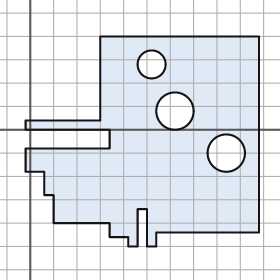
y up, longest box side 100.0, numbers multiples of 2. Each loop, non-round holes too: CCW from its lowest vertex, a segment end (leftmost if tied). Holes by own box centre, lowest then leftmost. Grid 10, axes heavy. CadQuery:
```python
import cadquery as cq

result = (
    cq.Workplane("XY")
    .moveTo(42.0, -50.0)
    .lineTo(46.0, -50.0)
    .lineTo(46.0, -34.0)
    .lineTo(50.0, -34.0)
    .lineTo(50.0, -50.0)
    .lineTo(54.0, -50.0)
    .lineTo(54.0, -44.0)
    .lineTo(98.0, -44.0)
    .lineTo(98.0, 40.0)
    .lineTo(30.0, 40.0)
    .lineTo(30.0, 4.0)
    .lineTo(-2.0, 4.0)
    .lineTo(-2.0, 0.0)
    .lineTo(34.0, 0.0)
    .lineTo(34.0, -8.0)
    .lineTo(-2.0, -8.0)
    .lineTo(-2.0, -18.0)
    .lineTo(6.0, -18.0)
    .lineTo(6.0, -28.0)
    .lineTo(10.0, -28.0)
    .lineTo(10.0, -40.0)
    .lineTo(34.0, -40.0)
    .lineTo(34.0, -46.0)
    .lineTo(42.0, -46.0)
    .close()
    .moveTo(84.0, -10.0)
    .circle(8.0)
    .moveTo(62.0, 8.0)
    .circle(8.0)
    .moveTo(52.0, 28.0)
    .circle(6.0)
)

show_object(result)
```